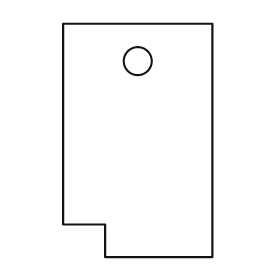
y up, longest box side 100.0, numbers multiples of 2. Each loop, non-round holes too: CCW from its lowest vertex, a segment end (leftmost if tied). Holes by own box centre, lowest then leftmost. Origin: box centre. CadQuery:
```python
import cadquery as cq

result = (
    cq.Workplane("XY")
    .moveTo(-14.0, -50.0)
    .lineTo(32.0, -50.0)
    .lineTo(32.0, 50.0)
    .lineTo(-32.0, 50.0)
    .lineTo(-32.0, -36.0)
    .lineTo(-14.0, -36.0)
    .close()
    .moveTo(0.0, 34.0)
    .circle(6.0)
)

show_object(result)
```